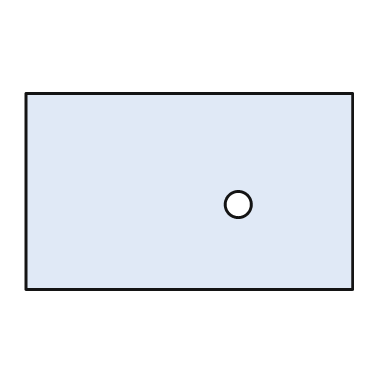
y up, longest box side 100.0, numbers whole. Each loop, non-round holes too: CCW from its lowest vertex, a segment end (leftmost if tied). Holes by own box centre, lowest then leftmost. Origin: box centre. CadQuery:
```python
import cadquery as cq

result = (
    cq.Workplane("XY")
    .moveTo(-50.0, -30.0)
    .lineTo(50.0, -30.0)
    .lineTo(50.0, 30.0)
    .lineTo(-50.0, 30.0)
    .close()
    .moveTo(15.0, -4.0)
    .circle(4.0)
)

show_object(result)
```